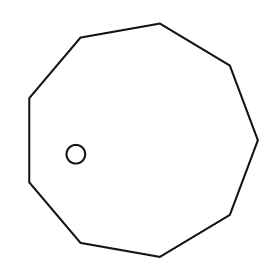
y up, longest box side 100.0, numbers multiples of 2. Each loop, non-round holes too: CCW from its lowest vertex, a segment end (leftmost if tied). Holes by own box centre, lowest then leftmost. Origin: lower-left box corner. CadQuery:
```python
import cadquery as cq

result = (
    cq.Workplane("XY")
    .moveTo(56.0, 0.0)
    .lineTo(86.0, 18.0)
    .lineTo(98.0, 50.0)
    .lineTo(86.0, 82.0)
    .lineTo(56.0, 100.0)
    .lineTo(22.0, 94.0)
    .lineTo(0.0, 68.0)
    .lineTo(0.0, 32.0)
    .lineTo(22.0, 6.0)
    .close()
    .moveTo(20.0, 44.0)
    .circle(4.0)
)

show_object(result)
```